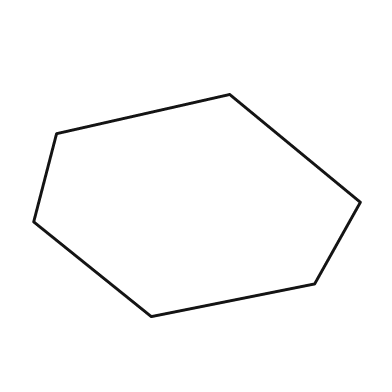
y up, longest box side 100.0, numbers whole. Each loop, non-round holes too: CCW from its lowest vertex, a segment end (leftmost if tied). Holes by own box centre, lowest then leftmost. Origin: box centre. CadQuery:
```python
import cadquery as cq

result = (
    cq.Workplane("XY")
    .moveTo(-14.0, -34.0)
    .lineTo(36.0, -24.0)
    .lineTo(50.0, 1.0)
    .lineTo(10.0, 34.0)
    .lineTo(-43.0, 22.0)
    .lineTo(-50.0, -5.0)
    .close()
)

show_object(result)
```